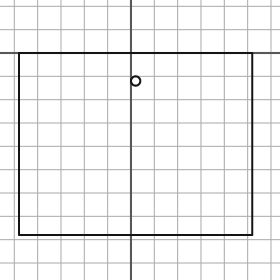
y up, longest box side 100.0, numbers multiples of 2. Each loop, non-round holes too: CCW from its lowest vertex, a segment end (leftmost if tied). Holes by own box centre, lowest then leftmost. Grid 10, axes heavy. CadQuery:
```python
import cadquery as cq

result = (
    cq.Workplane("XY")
    .moveTo(-48.0, -78.0)
    .lineTo(52.0, -78.0)
    .lineTo(52.0, 0.0)
    .lineTo(-48.0, 0.0)
    .close()
    .moveTo(2.0, -12.0)
    .circle(2.0)
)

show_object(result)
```